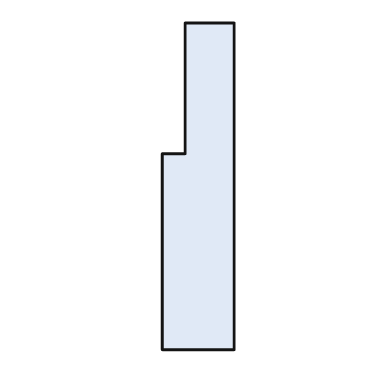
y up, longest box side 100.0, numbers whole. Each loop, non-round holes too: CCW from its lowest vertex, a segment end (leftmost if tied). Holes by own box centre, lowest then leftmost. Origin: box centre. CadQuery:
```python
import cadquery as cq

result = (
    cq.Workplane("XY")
    .moveTo(-11.0, -50.0)
    .lineTo(11.0, -50.0)
    .lineTo(11.0, 50.0)
    .lineTo(-4.0, 50.0)
    .lineTo(-4.0, 10.0)
    .lineTo(-11.0, 10.0)
    .close()
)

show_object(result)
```